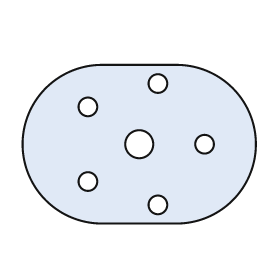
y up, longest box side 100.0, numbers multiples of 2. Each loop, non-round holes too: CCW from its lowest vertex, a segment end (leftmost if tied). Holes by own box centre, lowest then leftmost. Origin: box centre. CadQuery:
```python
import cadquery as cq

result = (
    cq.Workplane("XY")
    .moveTo(-16.0, -34.0)
    .lineTo(16.0, -34.0)
    .threePointArc((50.0, 0.0), (16.0, 34.0))
    .lineTo(-16.0, 34.0)
    .threePointArc((-50.0, 0.0), (-16.0, -34.0))
    .close()
    .moveTo(8.0, -26.0)
    .circle(4.0)
    .moveTo(-22.0, -16.0)
    .circle(4.0)
    .moveTo(0.0, 0.0)
    .circle(6.0)
    .moveTo(28.0, 0.0)
    .circle(4.0)
    .moveTo(-22.0, 16.0)
    .circle(4.0)
    .moveTo(8.0, 26.0)
    .circle(4.0)
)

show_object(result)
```